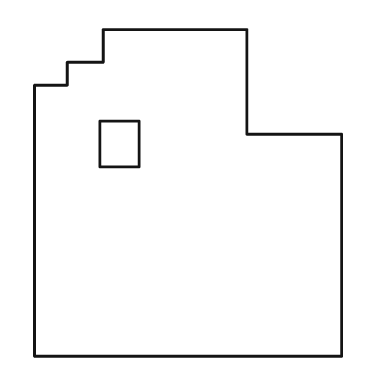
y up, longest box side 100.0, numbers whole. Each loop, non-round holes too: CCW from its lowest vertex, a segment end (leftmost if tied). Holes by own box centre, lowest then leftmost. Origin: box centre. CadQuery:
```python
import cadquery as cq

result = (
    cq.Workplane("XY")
    .moveTo(-47.0, -50.0)
    .lineTo(47.0, -50.0)
    .lineTo(47.0, 18.0)
    .lineTo(18.0, 18.0)
    .lineTo(18.0, 50.0)
    .lineTo(-26.0, 50.0)
    .lineTo(-26.0, 40.0)
    .lineTo(-37.0, 40.0)
    .lineTo(-37.0, 33.0)
    .lineTo(-47.0, 33.0)
    .close()
    .moveTo(-27.0, 8.0)
    .lineTo(-15.0, 8.0)
    .lineTo(-15.0, 22.0)
    .lineTo(-27.0, 22.0)
    .close()
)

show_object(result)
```